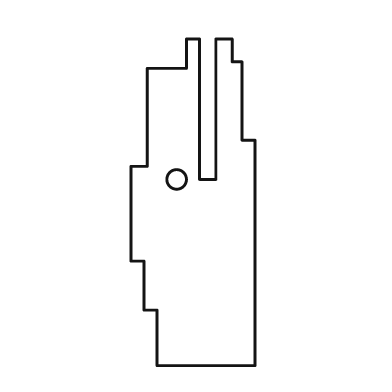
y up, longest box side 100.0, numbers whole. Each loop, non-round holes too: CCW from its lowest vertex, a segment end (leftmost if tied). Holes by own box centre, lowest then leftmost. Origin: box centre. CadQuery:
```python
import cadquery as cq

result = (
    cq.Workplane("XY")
    .moveTo(-11.0, -50.0)
    .lineTo(19.0, -50.0)
    .lineTo(19.0, 19.0)
    .lineTo(15.0, 19.0)
    .lineTo(15.0, 43.0)
    .lineTo(12.0, 43.0)
    .lineTo(12.0, 50.0)
    .lineTo(7.0, 50.0)
    .lineTo(7.0, 7.0)
    .lineTo(2.0, 7.0)
    .lineTo(2.0, 50.0)
    .lineTo(-2.0, 50.0)
    .lineTo(-2.0, 41.0)
    .lineTo(-14.0, 41.0)
    .lineTo(-14.0, 11.0)
    .lineTo(-19.0, 11.0)
    .lineTo(-19.0, -18.0)
    .lineTo(-15.0, -18.0)
    .lineTo(-15.0, -33.0)
    .lineTo(-11.0, -33.0)
    .close()
    .moveTo(-5.0, 7.0)
    .circle(3.0)
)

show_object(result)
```